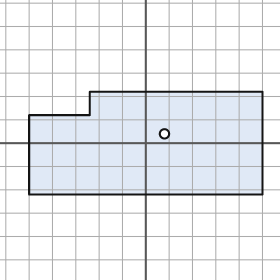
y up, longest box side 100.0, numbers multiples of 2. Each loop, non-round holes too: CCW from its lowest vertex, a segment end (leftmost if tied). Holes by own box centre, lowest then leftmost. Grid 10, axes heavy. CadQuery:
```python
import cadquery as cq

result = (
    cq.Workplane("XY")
    .moveTo(-50.0, -22.0)
    .lineTo(50.0, -22.0)
    .lineTo(50.0, 22.0)
    .lineTo(-24.0, 22.0)
    .lineTo(-24.0, 12.0)
    .lineTo(-50.0, 12.0)
    .close()
    .moveTo(8.0, 4.0)
    .circle(2.0)
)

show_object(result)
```